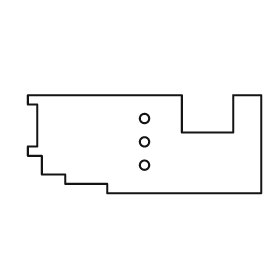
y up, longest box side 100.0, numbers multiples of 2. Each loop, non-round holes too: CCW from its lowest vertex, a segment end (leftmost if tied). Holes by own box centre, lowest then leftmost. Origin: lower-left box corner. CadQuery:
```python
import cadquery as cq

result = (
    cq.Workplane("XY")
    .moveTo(34.0, 0.0)
    .lineTo(100.0, 0.0)
    .lineTo(100.0, 42.0)
    .lineTo(88.0, 42.0)
    .lineTo(88.0, 26.0)
    .lineTo(66.0, 26.0)
    .lineTo(66.0, 42.0)
    .lineTo(0.0, 42.0)
    .lineTo(0.0, 38.0)
    .lineTo(4.0, 38.0)
    .lineTo(4.0, 20.0)
    .lineTo(0.0, 20.0)
    .lineTo(0.0, 16.0)
    .lineTo(6.0, 16.0)
    .lineTo(6.0, 8.0)
    .lineTo(16.0, 8.0)
    .lineTo(16.0, 4.0)
    .lineTo(34.0, 4.0)
    .close()
    .moveTo(50.0, 12.0)
    .circle(2.0)
    .moveTo(50.0, 22.0)
    .circle(2.0)
    .moveTo(50.0, 32.0)
    .circle(2.0)
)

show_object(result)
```